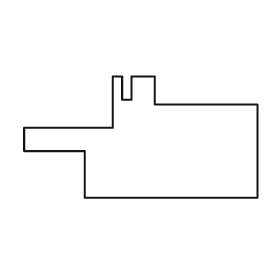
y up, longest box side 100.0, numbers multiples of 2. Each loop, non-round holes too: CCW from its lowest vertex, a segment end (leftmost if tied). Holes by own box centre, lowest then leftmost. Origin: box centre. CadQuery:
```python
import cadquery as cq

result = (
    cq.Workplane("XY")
    .moveTo(-24.0, -26.0)
    .lineTo(50.0, -26.0)
    .lineTo(50.0, 14.0)
    .lineTo(6.0, 14.0)
    .lineTo(6.0, 26.0)
    .lineTo(-4.0, 26.0)
    .lineTo(-4.0, 16.0)
    .lineTo(-8.0, 16.0)
    .lineTo(-8.0, 26.0)
    .lineTo(-12.0, 26.0)
    .lineTo(-12.0, 4.0)
    .lineTo(-50.0, 4.0)
    .lineTo(-50.0, -6.0)
    .lineTo(-24.0, -6.0)
    .close()
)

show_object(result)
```